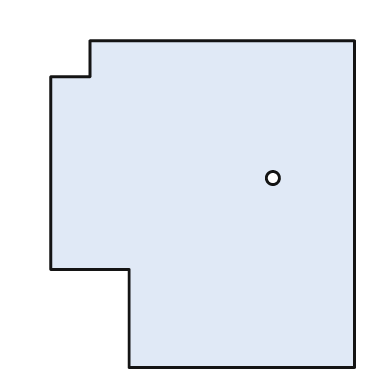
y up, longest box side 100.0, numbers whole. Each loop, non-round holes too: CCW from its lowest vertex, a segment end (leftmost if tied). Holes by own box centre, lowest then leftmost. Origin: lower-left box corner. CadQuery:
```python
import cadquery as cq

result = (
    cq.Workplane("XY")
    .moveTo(24.0, 0.0)
    .lineTo(93.0, 0.0)
    .lineTo(93.0, 100.0)
    .lineTo(12.0, 100.0)
    .lineTo(12.0, 89.0)
    .lineTo(0.0, 89.0)
    .lineTo(0.0, 30.0)
    .lineTo(24.0, 30.0)
    .close()
    .moveTo(68.0, 58.0)
    .circle(2.0)
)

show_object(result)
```